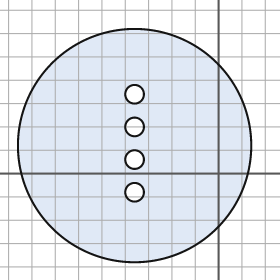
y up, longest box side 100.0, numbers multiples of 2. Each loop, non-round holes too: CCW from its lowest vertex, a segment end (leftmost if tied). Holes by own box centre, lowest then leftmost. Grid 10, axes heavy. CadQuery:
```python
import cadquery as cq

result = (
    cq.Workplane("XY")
    .moveTo(-36.0, 12.0)
    .circle(50.0)
    .moveTo(-36.0, -8.0)
    .circle(4.0)
    .moveTo(-36.0, 6.0)
    .circle(4.0)
    .moveTo(-36.0, 20.0)
    .circle(4.0)
    .moveTo(-36.0, 34.0)
    .circle(4.0)
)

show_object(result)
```